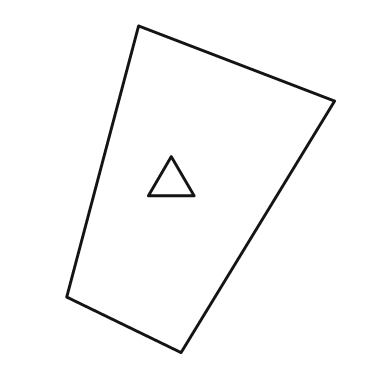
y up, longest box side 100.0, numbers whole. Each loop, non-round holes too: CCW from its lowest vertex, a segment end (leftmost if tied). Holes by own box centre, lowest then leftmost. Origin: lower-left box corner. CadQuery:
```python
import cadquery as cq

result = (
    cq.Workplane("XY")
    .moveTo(35.0, 0.0)
    .lineTo(82.0, 77.0)
    .lineTo(22.0, 100.0)
    .lineTo(0.0, 17.0)
    .close()
    .moveTo(25.0, 48.0)
    .lineTo(39.0, 48.0)
    .lineTo(32.0, 60.0)
    .close()
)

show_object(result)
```